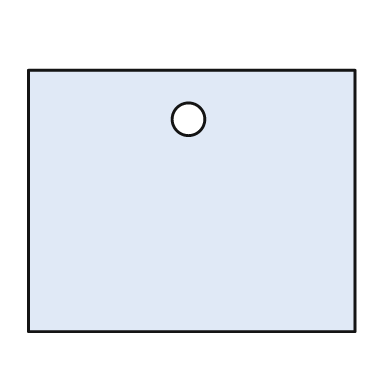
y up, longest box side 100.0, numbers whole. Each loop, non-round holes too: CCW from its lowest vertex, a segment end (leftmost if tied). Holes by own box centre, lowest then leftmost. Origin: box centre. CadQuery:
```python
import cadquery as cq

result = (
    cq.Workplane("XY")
    .moveTo(-50.0, -40.0)
    .lineTo(50.0, -40.0)
    .lineTo(50.0, 40.0)
    .lineTo(-50.0, 40.0)
    .close()
    .moveTo(-1.0, 25.0)
    .circle(5.0)
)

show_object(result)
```